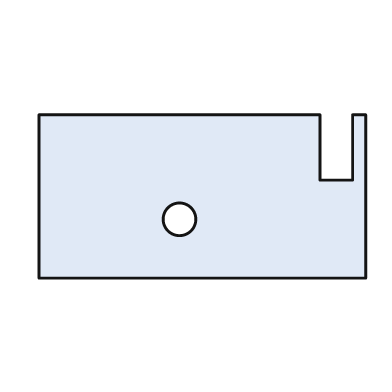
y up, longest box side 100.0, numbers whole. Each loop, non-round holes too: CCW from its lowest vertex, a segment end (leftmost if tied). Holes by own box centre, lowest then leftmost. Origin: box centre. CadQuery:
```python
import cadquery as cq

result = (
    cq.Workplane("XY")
    .moveTo(-50.0, -25.0)
    .lineTo(50.0, -25.0)
    .lineTo(50.0, 25.0)
    .lineTo(46.0, 25.0)
    .lineTo(46.0, 5.0)
    .lineTo(36.0, 5.0)
    .lineTo(36.0, 25.0)
    .lineTo(-50.0, 25.0)
    .close()
    .moveTo(-7.0, -7.0)
    .circle(5.0)
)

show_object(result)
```